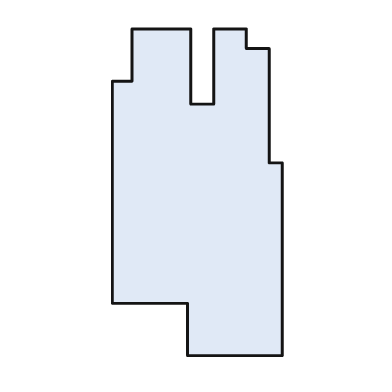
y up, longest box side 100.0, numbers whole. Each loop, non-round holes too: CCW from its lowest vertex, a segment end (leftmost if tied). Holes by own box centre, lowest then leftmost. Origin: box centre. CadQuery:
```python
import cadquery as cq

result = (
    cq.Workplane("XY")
    .moveTo(-3.0, -50.0)
    .lineTo(26.0, -50.0)
    .lineTo(26.0, 9.0)
    .lineTo(22.0, 9.0)
    .lineTo(22.0, 44.0)
    .lineTo(15.0, 44.0)
    .lineTo(15.0, 50.0)
    .lineTo(5.0, 50.0)
    .lineTo(5.0, 27.0)
    .lineTo(-2.0, 27.0)
    .lineTo(-2.0, 50.0)
    .lineTo(-20.0, 50.0)
    .lineTo(-20.0, 34.0)
    .lineTo(-26.0, 34.0)
    .lineTo(-26.0, -34.0)
    .lineTo(-3.0, -34.0)
    .close()
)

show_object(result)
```